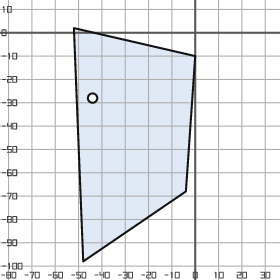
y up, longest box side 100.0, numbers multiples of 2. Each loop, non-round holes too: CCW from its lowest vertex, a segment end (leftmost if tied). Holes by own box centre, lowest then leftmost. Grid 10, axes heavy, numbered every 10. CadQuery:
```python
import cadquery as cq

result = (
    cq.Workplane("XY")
    .moveTo(-48.0, -98.0)
    .lineTo(-4.0, -68.0)
    .lineTo(0.0, -10.0)
    .lineTo(-52.0, 2.0)
    .close()
    .moveTo(-44.0, -28.0)
    .circle(2.0)
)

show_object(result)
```